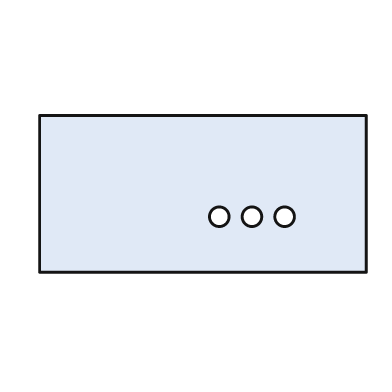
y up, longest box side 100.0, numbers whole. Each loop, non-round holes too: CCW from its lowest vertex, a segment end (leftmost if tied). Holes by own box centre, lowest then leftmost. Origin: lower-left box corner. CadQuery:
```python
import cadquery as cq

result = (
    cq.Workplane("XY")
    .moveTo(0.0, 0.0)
    .lineTo(100.0, 0.0)
    .lineTo(100.0, 48.0)
    .lineTo(0.0, 48.0)
    .close()
    .moveTo(55.0, 17.0)
    .circle(3.0)
    .moveTo(65.0, 17.0)
    .circle(3.0)
    .moveTo(75.0, 17.0)
    .circle(3.0)
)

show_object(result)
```